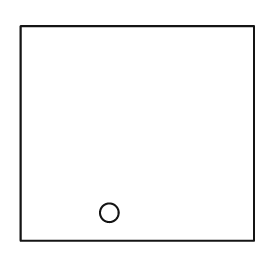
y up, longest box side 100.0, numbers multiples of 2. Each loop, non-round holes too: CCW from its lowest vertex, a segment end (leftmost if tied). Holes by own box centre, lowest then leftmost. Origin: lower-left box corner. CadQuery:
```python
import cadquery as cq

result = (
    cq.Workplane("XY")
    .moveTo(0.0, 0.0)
    .lineTo(100.0, 0.0)
    .lineTo(100.0, 92.0)
    .lineTo(0.0, 92.0)
    .close()
    .moveTo(38.0, 12.0)
    .circle(4.0)
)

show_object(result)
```